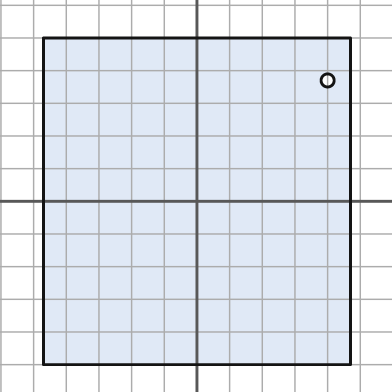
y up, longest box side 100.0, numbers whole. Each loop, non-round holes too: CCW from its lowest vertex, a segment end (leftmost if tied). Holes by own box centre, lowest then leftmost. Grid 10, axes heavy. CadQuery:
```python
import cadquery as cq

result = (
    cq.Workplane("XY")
    .moveTo(-47.0, -50.0)
    .lineTo(47.0, -50.0)
    .lineTo(47.0, 50.0)
    .lineTo(-47.0, 50.0)
    .close()
    .moveTo(40.0, 37.0)
    .circle(2.0)
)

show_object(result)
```